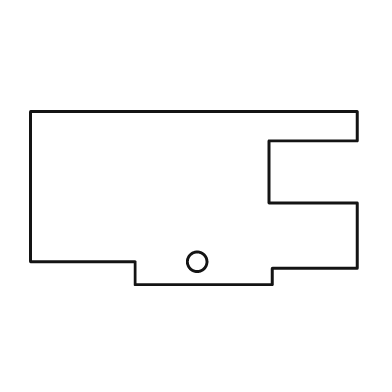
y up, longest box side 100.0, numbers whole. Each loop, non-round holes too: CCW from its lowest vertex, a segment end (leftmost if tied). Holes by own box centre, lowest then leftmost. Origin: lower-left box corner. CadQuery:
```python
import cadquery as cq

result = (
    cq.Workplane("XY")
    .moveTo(32.0, 0.0)
    .lineTo(74.0, 0.0)
    .lineTo(74.0, 5.0)
    .lineTo(100.0, 5.0)
    .lineTo(100.0, 25.0)
    .lineTo(73.0, 25.0)
    .lineTo(73.0, 44.0)
    .lineTo(100.0, 44.0)
    .lineTo(100.0, 53.0)
    .lineTo(0.0, 53.0)
    .lineTo(0.0, 7.0)
    .lineTo(32.0, 7.0)
    .close()
    .moveTo(51.0, 7.0)
    .circle(3.0)
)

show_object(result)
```